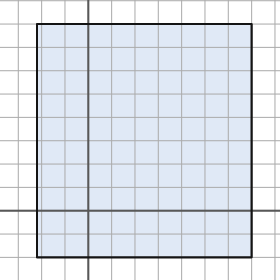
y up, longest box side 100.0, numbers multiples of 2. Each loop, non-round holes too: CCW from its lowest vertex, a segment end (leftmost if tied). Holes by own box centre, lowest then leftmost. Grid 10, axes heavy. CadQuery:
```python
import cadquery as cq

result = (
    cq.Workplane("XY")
    .moveTo(-22.0, -20.0)
    .lineTo(70.0, -20.0)
    .lineTo(70.0, 80.0)
    .lineTo(-22.0, 80.0)
    .close()
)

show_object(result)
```